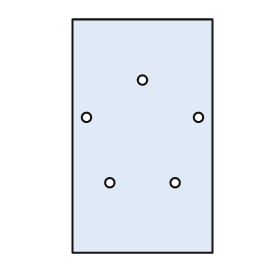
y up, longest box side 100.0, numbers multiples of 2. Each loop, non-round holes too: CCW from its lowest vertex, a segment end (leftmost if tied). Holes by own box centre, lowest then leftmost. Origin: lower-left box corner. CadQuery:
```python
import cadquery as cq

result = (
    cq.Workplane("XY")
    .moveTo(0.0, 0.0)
    .lineTo(60.0, 0.0)
    .lineTo(60.0, 100.0)
    .lineTo(0.0, 100.0)
    .close()
    .moveTo(16.0, 30.0)
    .circle(2.0)
    .moveTo(44.0, 30.0)
    .circle(2.0)
    .moveTo(6.0, 58.0)
    .circle(2.0)
    .moveTo(54.0, 58.0)
    .circle(2.0)
    .moveTo(30.0, 74.0)
    .circle(2.0)
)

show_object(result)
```